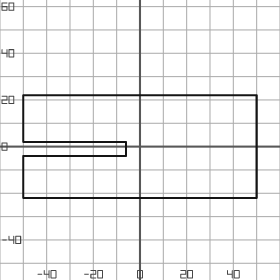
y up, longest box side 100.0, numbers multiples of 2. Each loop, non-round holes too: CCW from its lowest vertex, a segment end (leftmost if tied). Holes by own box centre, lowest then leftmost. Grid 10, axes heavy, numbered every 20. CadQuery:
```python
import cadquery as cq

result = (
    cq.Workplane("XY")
    .moveTo(-50.0, -22.0)
    .lineTo(50.0, -22.0)
    .lineTo(50.0, 22.0)
    .lineTo(-50.0, 22.0)
    .lineTo(-50.0, 2.0)
    .lineTo(-6.0, 2.0)
    .lineTo(-6.0, -4.0)
    .lineTo(-50.0, -4.0)
    .close()
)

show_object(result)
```